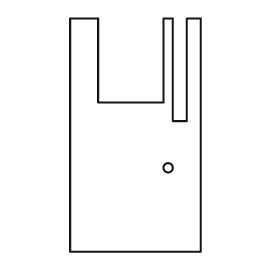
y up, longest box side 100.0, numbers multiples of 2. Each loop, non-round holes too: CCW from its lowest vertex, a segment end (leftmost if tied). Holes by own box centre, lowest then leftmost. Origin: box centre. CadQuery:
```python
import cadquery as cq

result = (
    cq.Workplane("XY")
    .moveTo(-28.0, -50.0)
    .lineTo(28.0, -50.0)
    .lineTo(28.0, 50.0)
    .lineTo(22.0, 50.0)
    .lineTo(22.0, 6.0)
    .lineTo(16.0, 6.0)
    .lineTo(16.0, 50.0)
    .lineTo(12.0, 50.0)
    .lineTo(12.0, 14.0)
    .lineTo(-16.0, 14.0)
    .lineTo(-16.0, 50.0)
    .lineTo(-28.0, 50.0)
    .close()
    .moveTo(14.0, -14.0)
    .circle(2.0)
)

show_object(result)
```